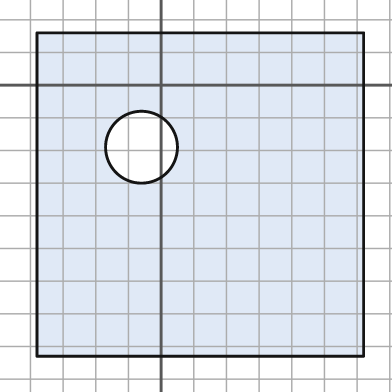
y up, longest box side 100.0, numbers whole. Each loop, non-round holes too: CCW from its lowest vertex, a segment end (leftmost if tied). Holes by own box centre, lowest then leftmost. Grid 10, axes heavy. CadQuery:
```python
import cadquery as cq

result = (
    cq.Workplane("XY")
    .moveTo(-38.0, -83.0)
    .lineTo(62.0, -83.0)
    .lineTo(62.0, 16.0)
    .lineTo(-38.0, 16.0)
    .close()
    .moveTo(-6.0, -19.0)
    .circle(11.0)
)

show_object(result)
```